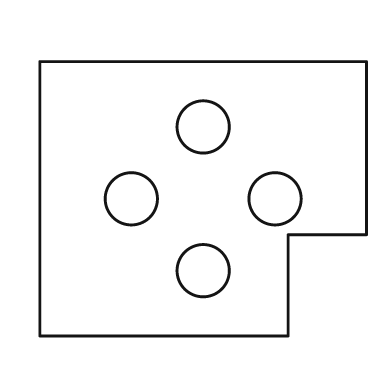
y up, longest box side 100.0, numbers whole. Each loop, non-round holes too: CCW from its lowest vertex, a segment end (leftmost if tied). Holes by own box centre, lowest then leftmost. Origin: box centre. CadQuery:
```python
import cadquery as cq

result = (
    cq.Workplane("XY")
    .moveTo(-50.0, -42.0)
    .lineTo(26.0, -42.0)
    .lineTo(26.0, -11.0)
    .lineTo(50.0, -11.0)
    .lineTo(50.0, 42.0)
    .lineTo(-50.0, 42.0)
    .close()
    .moveTo(0.0, -22.0)
    .circle(8.0)
    .moveTo(-22.0, 0.0)
    .circle(8.0)
    .moveTo(22.0, 0.0)
    .circle(8.0)
    .moveTo(0.0, 22.0)
    .circle(8.0)
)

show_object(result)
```